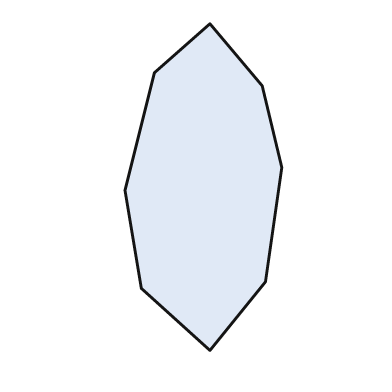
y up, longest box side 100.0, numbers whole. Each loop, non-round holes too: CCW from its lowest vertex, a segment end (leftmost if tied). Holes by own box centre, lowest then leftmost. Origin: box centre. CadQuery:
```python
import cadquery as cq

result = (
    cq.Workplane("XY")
    .moveTo(2.0, -50.0)
    .lineTo(19.0, -29.0)
    .lineTo(24.0, 6.0)
    .lineTo(18.0, 31.0)
    .lineTo(2.0, 50.0)
    .lineTo(-15.0, 35.0)
    .lineTo(-24.0, -1.0)
    .lineTo(-19.0, -31.0)
    .close()
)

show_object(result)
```